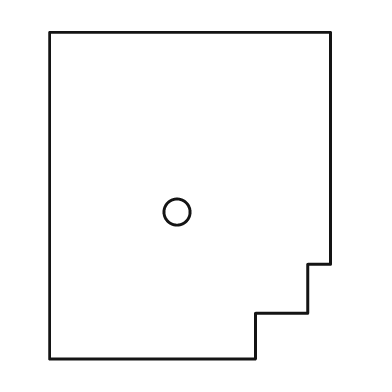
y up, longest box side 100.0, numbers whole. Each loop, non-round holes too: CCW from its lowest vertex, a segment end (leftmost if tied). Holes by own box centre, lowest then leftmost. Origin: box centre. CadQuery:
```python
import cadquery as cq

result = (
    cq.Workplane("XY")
    .moveTo(-43.0, -50.0)
    .lineTo(20.0, -50.0)
    .lineTo(20.0, -36.0)
    .lineTo(36.0, -36.0)
    .lineTo(36.0, -21.0)
    .lineTo(43.0, -21.0)
    .lineTo(43.0, 50.0)
    .lineTo(-43.0, 50.0)
    .close()
    .moveTo(-4.0, -5.0)
    .circle(4.0)
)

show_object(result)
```